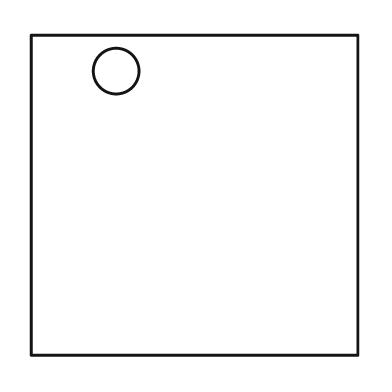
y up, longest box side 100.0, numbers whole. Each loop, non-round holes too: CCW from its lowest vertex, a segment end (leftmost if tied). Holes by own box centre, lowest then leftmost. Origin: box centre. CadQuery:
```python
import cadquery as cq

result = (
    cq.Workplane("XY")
    .moveTo(-50.0, -49.0)
    .lineTo(50.0, -49.0)
    .lineTo(50.0, 49.0)
    .lineTo(-50.0, 49.0)
    .close()
    .moveTo(-24.0, 38.0)
    .circle(7.0)
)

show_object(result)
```